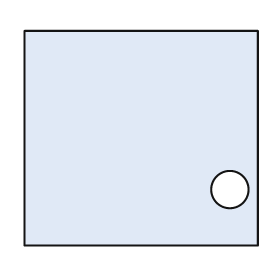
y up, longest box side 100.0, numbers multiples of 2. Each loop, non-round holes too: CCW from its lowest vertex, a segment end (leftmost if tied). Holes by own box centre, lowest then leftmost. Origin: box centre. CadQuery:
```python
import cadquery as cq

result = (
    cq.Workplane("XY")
    .moveTo(-50.0, -46.0)
    .lineTo(50.0, -46.0)
    .lineTo(50.0, 46.0)
    .lineTo(-50.0, 46.0)
    .close()
    .moveTo(38.0, -22.0)
    .circle(8.0)
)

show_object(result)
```